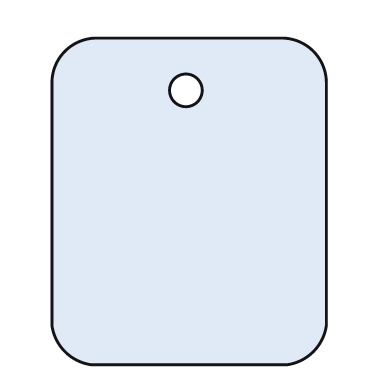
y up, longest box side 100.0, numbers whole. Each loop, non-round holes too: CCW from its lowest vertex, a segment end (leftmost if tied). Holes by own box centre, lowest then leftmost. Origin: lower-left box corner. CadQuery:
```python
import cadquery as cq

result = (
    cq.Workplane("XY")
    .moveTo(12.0, 0.0)
    .lineTo(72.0, 0.0)
    .threePointArc((80.0, 4.0), (84.0, 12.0))
    .lineTo(84.0, 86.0)
    .threePointArc((80.0, 96.0), (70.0, 100.0))
    .lineTo(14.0, 100.0)
    .threePointArc((4.0, 96.0), (0.0, 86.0))
    .lineTo(0.0, 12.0)
    .threePointArc((4.0, 4.0), (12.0, 0.0))
    .close()
    .moveTo(41.0, 84.0)
    .circle(5.0)
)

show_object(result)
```